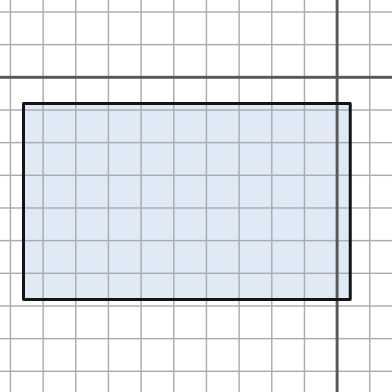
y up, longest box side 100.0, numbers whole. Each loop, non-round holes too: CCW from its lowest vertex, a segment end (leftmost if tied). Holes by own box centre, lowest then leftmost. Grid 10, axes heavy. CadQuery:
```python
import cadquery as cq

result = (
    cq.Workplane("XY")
    .moveTo(-96.0, -68.0)
    .lineTo(4.0, -68.0)
    .lineTo(4.0, -8.0)
    .lineTo(-96.0, -8.0)
    .close()
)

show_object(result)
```